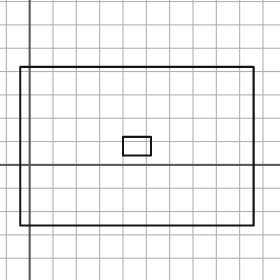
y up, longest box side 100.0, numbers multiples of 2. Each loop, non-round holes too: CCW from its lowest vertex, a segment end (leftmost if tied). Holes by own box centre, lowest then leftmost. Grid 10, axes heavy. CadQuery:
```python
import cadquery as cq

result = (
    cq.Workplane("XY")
    .moveTo(-4.0, -26.0)
    .lineTo(96.0, -26.0)
    .lineTo(96.0, 42.0)
    .lineTo(-4.0, 42.0)
    .close()
    .moveTo(40.0, 4.0)
    .lineTo(52.0, 4.0)
    .lineTo(52.0, 12.0)
    .lineTo(40.0, 12.0)
    .close()
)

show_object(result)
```